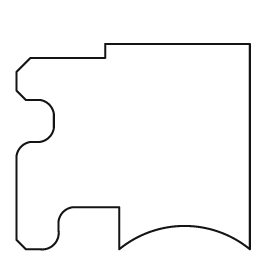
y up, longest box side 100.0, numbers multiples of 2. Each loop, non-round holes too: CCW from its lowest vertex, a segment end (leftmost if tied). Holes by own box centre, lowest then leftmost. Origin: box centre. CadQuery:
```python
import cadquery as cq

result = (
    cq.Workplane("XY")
    .moveTo(-46.0, -44.0)
    .lineTo(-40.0, -44.0)
    .threePointArc((-34.0, -42.0), (-32.0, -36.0))
    .lineTo(-32.0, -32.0)
    .threePointArc((-30.0, -28.0), (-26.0, -26.0))
    .lineTo(-6.0, -26.0)
    .lineTo(-6.0, -44.0)
    .threePointArc((22.0, -34.0), (50.0, -44.0))
    .lineTo(50.0, 44.0)
    .lineTo(-12.0, 44.0)
    .lineTo(-12.0, 38.0)
    .lineTo(-44.0, 38.0)
    .lineTo(-50.0, 32.0)
    .lineTo(-50.0, 24.0)
    .lineTo(-46.0, 20.0)
    .lineTo(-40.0, 20.0)
    .threePointArc((-36.0, 18.0), (-34.0, 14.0))
    .lineTo(-34.0, 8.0)
    .threePointArc((-36.0, 4.0), (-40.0, 2.0))
    .lineTo(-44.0, 2.0)
    .threePointArc((-48.0, 0.0), (-50.0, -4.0))
    .lineTo(-50.0, -40.0)
    .close()
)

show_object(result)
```